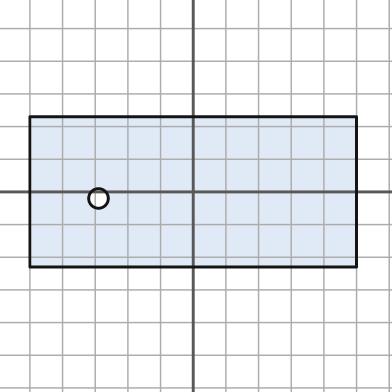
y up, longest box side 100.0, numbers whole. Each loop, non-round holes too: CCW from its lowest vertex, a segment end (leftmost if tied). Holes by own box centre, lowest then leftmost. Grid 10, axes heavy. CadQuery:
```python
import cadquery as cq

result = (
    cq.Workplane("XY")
    .moveTo(-50.0, -23.0)
    .lineTo(50.0, -23.0)
    .lineTo(50.0, 23.0)
    .lineTo(-50.0, 23.0)
    .close()
    .moveTo(-29.0, -2.0)
    .circle(3.0)
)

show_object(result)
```